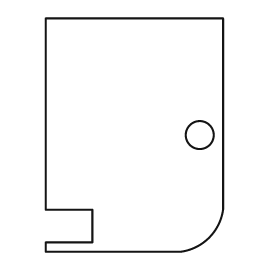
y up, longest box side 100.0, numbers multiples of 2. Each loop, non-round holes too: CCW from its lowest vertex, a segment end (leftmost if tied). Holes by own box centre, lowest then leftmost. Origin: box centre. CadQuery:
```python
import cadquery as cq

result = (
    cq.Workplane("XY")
    .moveTo(-38.0, -50.0)
    .lineTo(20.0, -50.0)
    .threePointArc((32.0, -44.0), (38.0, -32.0))
    .lineTo(38.0, 50.0)
    .lineTo(-38.0, 50.0)
    .lineTo(-38.0, -32.0)
    .lineTo(-18.0, -32.0)
    .lineTo(-18.0, -46.0)
    .lineTo(-38.0, -46.0)
    .close()
    .moveTo(28.0, 0.0)
    .circle(6.0)
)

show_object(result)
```